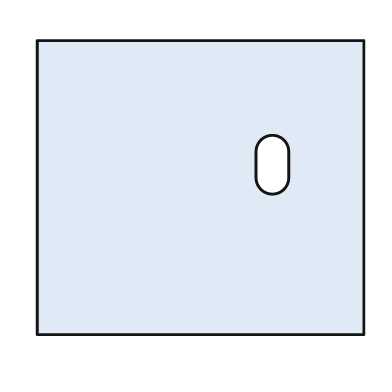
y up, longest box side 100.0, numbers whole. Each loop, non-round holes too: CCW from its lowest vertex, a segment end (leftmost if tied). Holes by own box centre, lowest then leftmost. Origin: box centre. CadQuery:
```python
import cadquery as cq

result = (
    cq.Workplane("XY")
    .moveTo(-50.0, -45.0)
    .lineTo(50.0, -45.0)
    .lineTo(50.0, 45.0)
    .lineTo(-50.0, 45.0)
    .close()
    .moveTo(17.0, 3.0)
    .threePointArc((22.0, -2.0), (27.0, 3.0))
    .lineTo(27.0, 11.0)
    .threePointArc((22.0, 16.0), (17.0, 11.0))
    .close()
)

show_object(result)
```